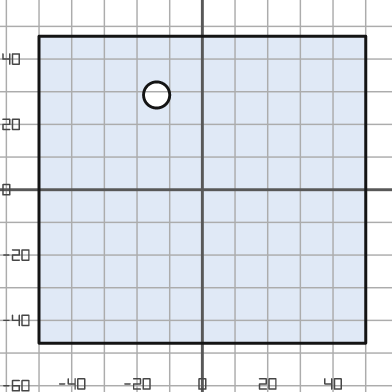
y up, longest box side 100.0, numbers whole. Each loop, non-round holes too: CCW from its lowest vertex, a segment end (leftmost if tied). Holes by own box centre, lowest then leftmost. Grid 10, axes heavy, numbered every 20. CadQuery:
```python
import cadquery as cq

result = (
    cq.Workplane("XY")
    .moveTo(-50.0, -47.0)
    .lineTo(50.0, -47.0)
    .lineTo(50.0, 47.0)
    .lineTo(-50.0, 47.0)
    .close()
    .moveTo(-14.0, 29.0)
    .circle(4.0)
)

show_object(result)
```